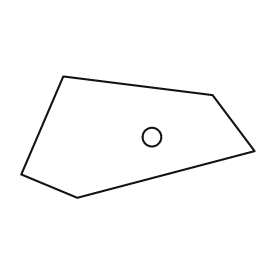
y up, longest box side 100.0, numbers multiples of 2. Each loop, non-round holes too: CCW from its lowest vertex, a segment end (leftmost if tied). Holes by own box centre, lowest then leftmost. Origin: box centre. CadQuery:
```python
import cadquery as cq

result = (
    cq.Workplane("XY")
    .moveTo(-26.0, -26.0)
    .lineTo(50.0, -6.0)
    .lineTo(32.0, 18.0)
    .lineTo(-32.0, 26.0)
    .lineTo(-50.0, -16.0)
    .close()
    .moveTo(6.0, 0.0)
    .circle(4.0)
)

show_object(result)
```